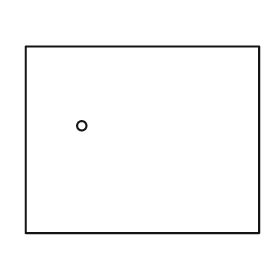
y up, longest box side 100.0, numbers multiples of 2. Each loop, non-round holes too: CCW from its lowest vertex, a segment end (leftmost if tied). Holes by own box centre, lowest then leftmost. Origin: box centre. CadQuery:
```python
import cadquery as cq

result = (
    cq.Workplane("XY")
    .moveTo(-50.0, -40.0)
    .lineTo(50.0, -40.0)
    .lineTo(50.0, 40.0)
    .lineTo(-50.0, 40.0)
    .close()
    .moveTo(-26.0, 6.0)
    .circle(2.0)
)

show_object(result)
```